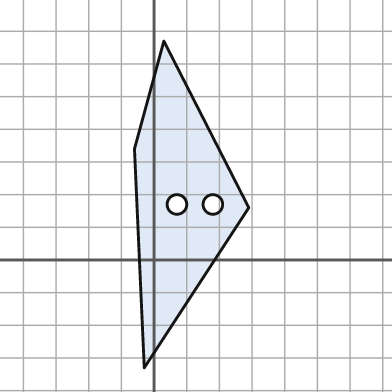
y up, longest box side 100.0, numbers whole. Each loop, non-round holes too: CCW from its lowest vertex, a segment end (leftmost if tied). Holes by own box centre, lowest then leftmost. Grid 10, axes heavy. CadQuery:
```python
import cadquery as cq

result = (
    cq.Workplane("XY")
    .moveTo(-3.0, -33.0)
    .lineTo(29.0, 16.0)
    .lineTo(3.0, 67.0)
    .lineTo(-6.0, 34.0)
    .close()
    .moveTo(7.0, 17.0)
    .circle(3.0)
    .moveTo(18.0, 17.0)
    .circle(3.0)
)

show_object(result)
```